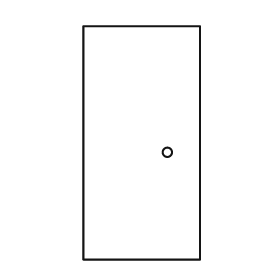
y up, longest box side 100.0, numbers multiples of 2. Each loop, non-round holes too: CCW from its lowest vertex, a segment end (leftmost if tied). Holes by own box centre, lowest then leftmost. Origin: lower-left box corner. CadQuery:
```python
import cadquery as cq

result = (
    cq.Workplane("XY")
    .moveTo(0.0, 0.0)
    .lineTo(50.0, 0.0)
    .lineTo(50.0, 100.0)
    .lineTo(0.0, 100.0)
    .close()
    .moveTo(36.0, 46.0)
    .circle(2.0)
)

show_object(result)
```